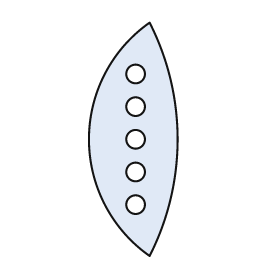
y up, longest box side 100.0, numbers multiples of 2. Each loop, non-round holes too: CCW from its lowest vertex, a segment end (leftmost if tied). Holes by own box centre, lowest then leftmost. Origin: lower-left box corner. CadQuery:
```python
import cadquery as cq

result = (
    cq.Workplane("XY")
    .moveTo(26.0, 0.0)
    .threePointArc((38.0, 50.0), (26.0, 100.0))
    .threePointArc((0.0, 50.0), (26.0, 0.0))
    .close()
    .moveTo(20.0, 22.0)
    .circle(4.0)
    .moveTo(20.0, 36.0)
    .circle(4.0)
    .moveTo(20.0, 50.0)
    .circle(4.0)
    .moveTo(20.0, 64.0)
    .circle(4.0)
    .moveTo(20.0, 78.0)
    .circle(4.0)
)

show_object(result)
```